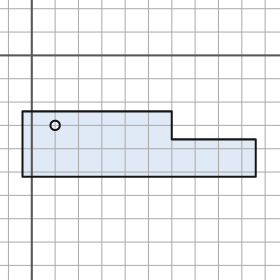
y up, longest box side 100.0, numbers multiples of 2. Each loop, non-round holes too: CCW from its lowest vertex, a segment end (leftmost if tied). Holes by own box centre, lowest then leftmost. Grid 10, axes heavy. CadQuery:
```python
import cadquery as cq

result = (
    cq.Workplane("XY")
    .moveTo(-4.0, -52.0)
    .lineTo(96.0, -52.0)
    .lineTo(96.0, -36.0)
    .lineTo(60.0, -36.0)
    .lineTo(60.0, -24.0)
    .lineTo(-4.0, -24.0)
    .close()
    .moveTo(10.0, -30.0)
    .circle(2.0)
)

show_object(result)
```